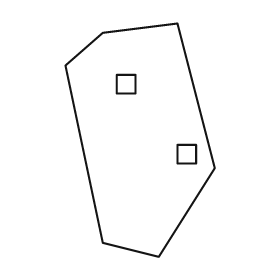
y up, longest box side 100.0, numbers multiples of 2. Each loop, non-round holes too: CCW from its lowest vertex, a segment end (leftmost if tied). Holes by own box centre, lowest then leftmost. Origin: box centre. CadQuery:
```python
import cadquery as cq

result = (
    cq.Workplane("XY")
    .moveTo(8.0, -50.0)
    .lineTo(32.0, -12.0)
    .lineTo(16.0, 50.0)
    .lineTo(-16.0, 46.0)
    .lineTo(-32.0, 32.0)
    .lineTo(-16.0, -44.0)
    .close()
    .moveTo(16.0, -10.0)
    .lineTo(24.0, -10.0)
    .lineTo(24.0, -2.0)
    .lineTo(16.0, -2.0)
    .close()
    .moveTo(-10.0, 20.0)
    .lineTo(-2.0, 20.0)
    .lineTo(-2.0, 28.0)
    .lineTo(-10.0, 28.0)
    .close()
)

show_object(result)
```